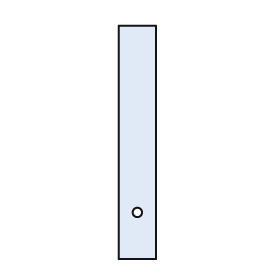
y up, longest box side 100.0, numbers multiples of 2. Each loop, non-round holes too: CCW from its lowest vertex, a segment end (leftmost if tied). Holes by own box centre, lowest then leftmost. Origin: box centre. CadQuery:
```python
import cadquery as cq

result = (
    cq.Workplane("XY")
    .moveTo(-8.0, -50.0)
    .lineTo(8.0, -50.0)
    .lineTo(8.0, 50.0)
    .lineTo(-8.0, 50.0)
    .close()
    .moveTo(0.0, -30.0)
    .circle(2.0)
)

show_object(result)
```